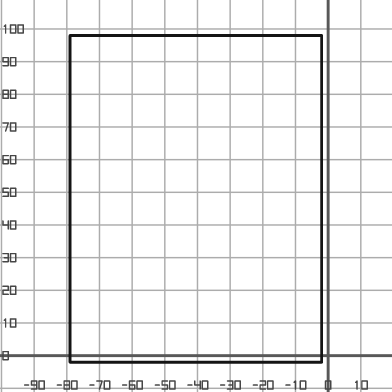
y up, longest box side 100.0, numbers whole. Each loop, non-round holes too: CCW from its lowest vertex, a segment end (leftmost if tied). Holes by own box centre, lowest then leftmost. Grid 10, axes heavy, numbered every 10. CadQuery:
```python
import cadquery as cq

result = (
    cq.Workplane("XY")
    .moveTo(-79.0, -2.0)
    .lineTo(-2.0, -2.0)
    .lineTo(-2.0, 98.0)
    .lineTo(-79.0, 98.0)
    .close()
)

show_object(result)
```